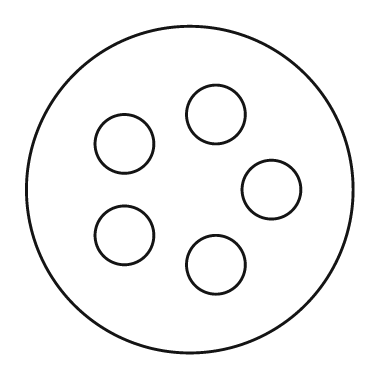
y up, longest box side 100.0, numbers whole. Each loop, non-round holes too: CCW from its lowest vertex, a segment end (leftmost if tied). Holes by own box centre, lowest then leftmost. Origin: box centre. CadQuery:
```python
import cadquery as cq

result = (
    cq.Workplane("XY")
    .moveTo(0.0, 0.0)
    .circle(50.0)
    .moveTo(8.0, -23.0)
    .circle(9.0)
    .moveTo(-20.0, -14.0)
    .circle(9.0)
    .moveTo(25.0, 0.0)
    .circle(9.0)
    .moveTo(-20.0, 14.0)
    .circle(9.0)
    .moveTo(8.0, 23.0)
    .circle(9.0)
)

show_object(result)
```